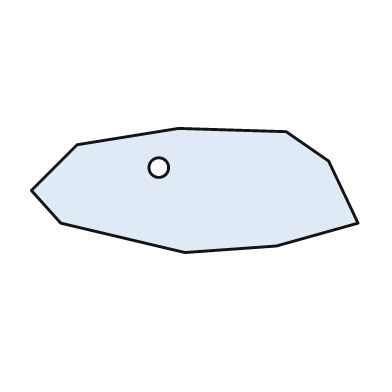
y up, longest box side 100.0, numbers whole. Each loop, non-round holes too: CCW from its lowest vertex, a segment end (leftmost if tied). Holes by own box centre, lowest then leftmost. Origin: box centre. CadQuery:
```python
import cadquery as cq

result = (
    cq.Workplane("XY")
    .moveTo(-3.0, -19.0)
    .lineTo(25.0, -17.0)
    .lineTo(50.0, -10.0)
    .lineTo(41.0, 9.0)
    .lineTo(28.0, 18.0)
    .lineTo(-5.0, 19.0)
    .lineTo(-36.0, 14.0)
    .lineTo(-50.0, 0.0)
    .lineTo(-41.0, -10.0)
    .close()
    .moveTo(-11.0, 7.0)
    .circle(3.0)
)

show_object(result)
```